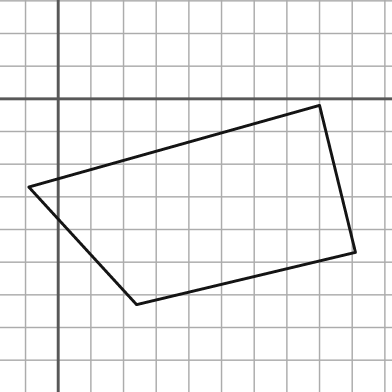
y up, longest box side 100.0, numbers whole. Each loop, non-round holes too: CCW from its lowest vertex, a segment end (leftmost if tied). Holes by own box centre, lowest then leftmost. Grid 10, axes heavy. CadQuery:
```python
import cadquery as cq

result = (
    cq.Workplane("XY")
    .moveTo(24.0, -63.0)
    .lineTo(91.0, -47.0)
    .lineTo(80.0, -2.0)
    .lineTo(-9.0, -27.0)
    .close()
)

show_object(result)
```